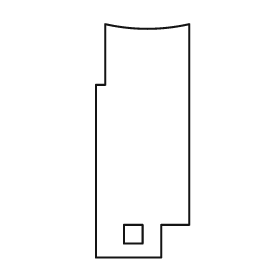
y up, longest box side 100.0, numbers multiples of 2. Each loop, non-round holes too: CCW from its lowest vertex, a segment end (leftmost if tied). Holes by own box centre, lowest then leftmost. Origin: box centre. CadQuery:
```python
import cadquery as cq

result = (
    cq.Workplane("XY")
    .moveTo(-20.0, -50.0)
    .lineTo(8.0, -50.0)
    .lineTo(8.0, -36.0)
    .lineTo(20.0, -36.0)
    .lineTo(20.0, 50.0)
    .threePointArc((2.0, 48.0), (-16.0, 50.0))
    .lineTo(-16.0, 24.0)
    .lineTo(-20.0, 24.0)
    .close()
    .moveTo(-8.0, -44.0)
    .lineTo(0.0, -44.0)
    .lineTo(0.0, -36.0)
    .lineTo(-8.0, -36.0)
    .close()
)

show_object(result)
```